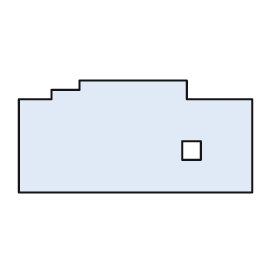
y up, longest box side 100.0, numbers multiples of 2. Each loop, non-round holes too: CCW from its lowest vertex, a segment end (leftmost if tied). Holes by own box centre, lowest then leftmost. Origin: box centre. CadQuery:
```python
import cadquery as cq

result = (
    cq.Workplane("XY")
    .moveTo(-50.0, -24.0)
    .lineTo(50.0, -24.0)
    .lineTo(50.0, 16.0)
    .lineTo(22.0, 16.0)
    .lineTo(22.0, 24.0)
    .lineTo(-24.0, 24.0)
    .lineTo(-24.0, 20.0)
    .lineTo(-36.0, 20.0)
    .lineTo(-36.0, 16.0)
    .lineTo(-50.0, 16.0)
    .close()
    .moveTo(20.0, -10.0)
    .lineTo(28.0, -10.0)
    .lineTo(28.0, -2.0)
    .lineTo(20.0, -2.0)
    .close()
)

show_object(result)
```